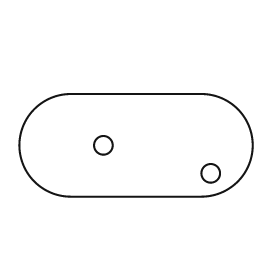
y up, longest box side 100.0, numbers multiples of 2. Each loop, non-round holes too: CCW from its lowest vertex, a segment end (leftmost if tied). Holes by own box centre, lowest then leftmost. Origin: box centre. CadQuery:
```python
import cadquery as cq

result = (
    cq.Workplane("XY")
    .moveTo(-28.0, -22.0)
    .lineTo(28.0, -22.0)
    .threePointArc((50.0, 0.0), (28.0, 22.0))
    .lineTo(-28.0, 22.0)
    .threePointArc((-50.0, 0.0), (-28.0, -22.0))
    .close()
    .moveTo(32.0, -12.0)
    .circle(4.0)
    .moveTo(-14.0, 0.0)
    .circle(4.0)
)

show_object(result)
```